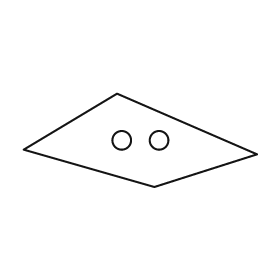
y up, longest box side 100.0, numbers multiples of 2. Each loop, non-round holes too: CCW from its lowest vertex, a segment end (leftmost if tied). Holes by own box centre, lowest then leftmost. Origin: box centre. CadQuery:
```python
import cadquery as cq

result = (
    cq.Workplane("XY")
    .moveTo(6.0, -20.0)
    .lineTo(50.0, -6.0)
    .lineTo(-10.0, 20.0)
    .lineTo(-50.0, -4.0)
    .close()
    .moveTo(-8.0, 0.0)
    .circle(4.0)
    .moveTo(8.0, 0.0)
    .circle(4.0)
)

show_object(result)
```